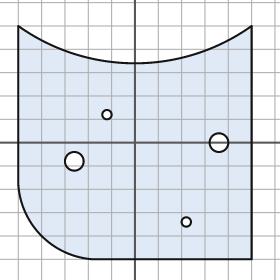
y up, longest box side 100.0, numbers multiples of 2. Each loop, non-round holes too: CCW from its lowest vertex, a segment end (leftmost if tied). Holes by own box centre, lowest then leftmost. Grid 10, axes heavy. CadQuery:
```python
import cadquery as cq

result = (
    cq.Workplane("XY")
    .moveTo(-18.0, -50.0)
    .lineTo(50.0, -50.0)
    .lineTo(50.0, 50.0)
    .threePointArc((0.0, 34.0), (-50.0, 50.0))
    .lineTo(-50.0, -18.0)
    .threePointArc((-40.0, -40.0), (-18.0, -50.0))
    .close()
    .moveTo(22.0, -34.0)
    .circle(2.0)
    .moveTo(-26.0, -8.0)
    .circle(4.0)
    .moveTo(36.0, 0.0)
    .circle(4.0)
    .moveTo(-12.0, 12.0)
    .circle(2.0)
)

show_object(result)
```